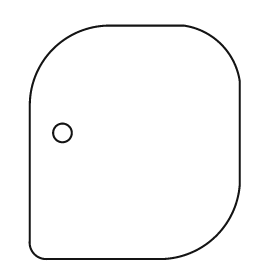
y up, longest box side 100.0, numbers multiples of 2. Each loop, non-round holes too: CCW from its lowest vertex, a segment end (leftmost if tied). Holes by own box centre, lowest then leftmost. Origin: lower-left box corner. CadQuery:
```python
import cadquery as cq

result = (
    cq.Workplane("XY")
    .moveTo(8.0, 0.0)
    .lineTo(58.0, 0.0)
    .threePointArc((80.0, 10.0), (90.0, 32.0))
    .lineTo(90.0, 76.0)
    .threePointArc((82.0, 92.0), (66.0, 100.0))
    .lineTo(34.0, 100.0)
    .threePointArc((10.0, 90.0), (0.0, 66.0))
    .lineTo(0.0, 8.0)
    .threePointArc((2.0, 2.0), (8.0, 0.0))
    .close()
    .moveTo(14.0, 54.0)
    .circle(4.0)
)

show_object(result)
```